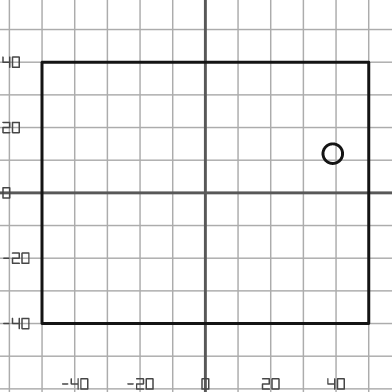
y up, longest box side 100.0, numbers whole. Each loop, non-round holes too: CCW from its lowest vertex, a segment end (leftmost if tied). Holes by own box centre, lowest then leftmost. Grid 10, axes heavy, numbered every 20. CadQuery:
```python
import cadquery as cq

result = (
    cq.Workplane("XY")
    .moveTo(-50.0, -40.0)
    .lineTo(50.0, -40.0)
    .lineTo(50.0, 40.0)
    .lineTo(-50.0, 40.0)
    .close()
    .moveTo(39.0, 12.0)
    .circle(3.0)
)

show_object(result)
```